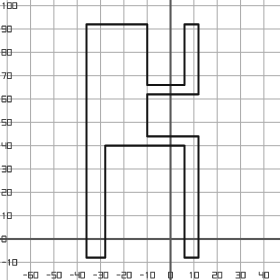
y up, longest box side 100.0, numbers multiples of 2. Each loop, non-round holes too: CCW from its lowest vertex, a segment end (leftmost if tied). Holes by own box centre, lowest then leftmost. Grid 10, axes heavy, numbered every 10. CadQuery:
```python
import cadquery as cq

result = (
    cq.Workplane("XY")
    .moveTo(-36.0, -8.0)
    .lineTo(-28.0, -8.0)
    .lineTo(-28.0, 40.0)
    .lineTo(6.0, 40.0)
    .lineTo(6.0, -8.0)
    .lineTo(12.0, -8.0)
    .lineTo(12.0, 44.0)
    .lineTo(-10.0, 44.0)
    .lineTo(-10.0, 62.0)
    .lineTo(12.0, 62.0)
    .lineTo(12.0, 92.0)
    .lineTo(6.0, 92.0)
    .lineTo(6.0, 66.0)
    .lineTo(-10.0, 66.0)
    .lineTo(-10.0, 92.0)
    .lineTo(-36.0, 92.0)
    .close()
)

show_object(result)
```